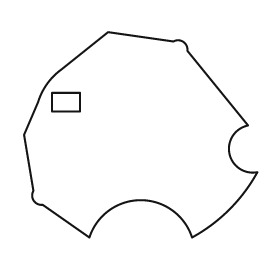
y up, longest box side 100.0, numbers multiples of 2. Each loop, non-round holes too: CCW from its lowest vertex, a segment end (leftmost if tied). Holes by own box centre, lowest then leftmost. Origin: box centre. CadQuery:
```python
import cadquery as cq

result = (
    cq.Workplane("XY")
    .moveTo(-22.0, -44.0)
    .threePointArc((0.0, -28.0), (22.0, -44.0))
    .threePointArc((38.0, -32.0), (50.0, -16.0))
    .threePointArc((38.0, -8.0), (46.0, 4.0))
    .lineTo(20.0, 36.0)
    .threePointArc((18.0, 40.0), (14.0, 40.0))
    .lineTo(-14.0, 44.0)
    .lineTo(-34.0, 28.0)
    .threePointArc((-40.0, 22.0), (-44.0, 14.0))
    .lineTo(-50.0, 0.0)
    .lineTo(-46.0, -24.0)
    .threePointArc((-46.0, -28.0), (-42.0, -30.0))
    .close()
    .moveTo(-38.0, 10.0)
    .lineTo(-26.0, 10.0)
    .lineTo(-26.0, 18.0)
    .lineTo(-38.0, 18.0)
    .close()
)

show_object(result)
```